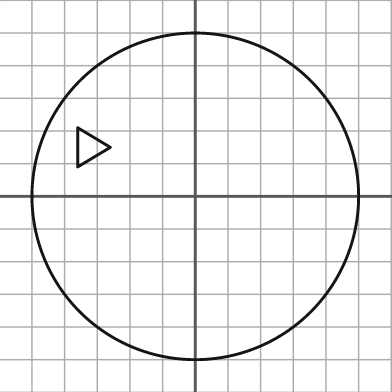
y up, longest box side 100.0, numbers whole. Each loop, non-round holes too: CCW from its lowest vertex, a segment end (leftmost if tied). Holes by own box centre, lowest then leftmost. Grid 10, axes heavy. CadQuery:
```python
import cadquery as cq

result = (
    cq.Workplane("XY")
    .moveTo(0.0, 0.0)
    .circle(50.0)
    .moveTo(-36.0, 9.0)
    .lineTo(-26.0, 15.0)
    .lineTo(-36.0, 21.0)
    .close()
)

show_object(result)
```